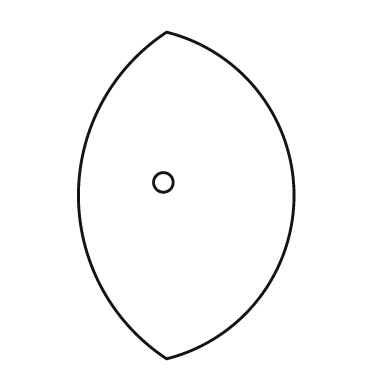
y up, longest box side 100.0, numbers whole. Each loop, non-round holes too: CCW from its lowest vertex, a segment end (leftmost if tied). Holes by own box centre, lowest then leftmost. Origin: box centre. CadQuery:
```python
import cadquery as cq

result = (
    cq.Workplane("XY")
    .moveTo(-6.0, -50.0)
    .threePointArc((33.0, 0.0), (-6.0, 50.0))
    .threePointArc((-33.0, 0.0), (-6.0, -50.0))
    .close()
    .moveTo(-7.0, 4.0)
    .circle(3.0)
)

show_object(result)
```